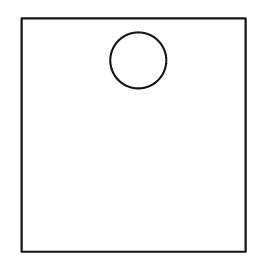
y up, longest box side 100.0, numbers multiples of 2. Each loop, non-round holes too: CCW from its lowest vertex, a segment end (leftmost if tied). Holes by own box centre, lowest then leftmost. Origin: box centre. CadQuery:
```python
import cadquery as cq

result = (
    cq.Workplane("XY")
    .moveTo(-48.0, -50.0)
    .lineTo(48.0, -50.0)
    .lineTo(48.0, 50.0)
    .lineTo(-48.0, 50.0)
    .close()
    .moveTo(2.0, 32.0)
    .circle(12.0)
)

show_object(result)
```